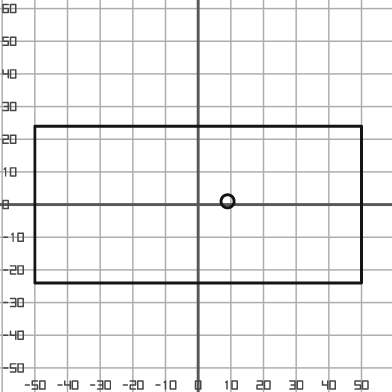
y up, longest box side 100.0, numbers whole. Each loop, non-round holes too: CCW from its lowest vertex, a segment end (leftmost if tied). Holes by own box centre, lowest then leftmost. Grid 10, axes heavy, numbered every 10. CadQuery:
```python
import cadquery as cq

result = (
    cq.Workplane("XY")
    .moveTo(-50.0, -24.0)
    .lineTo(50.0, -24.0)
    .lineTo(50.0, 24.0)
    .lineTo(-50.0, 24.0)
    .close()
    .moveTo(9.0, 1.0)
    .circle(2.0)
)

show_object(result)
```